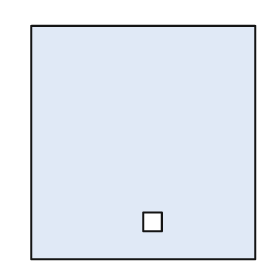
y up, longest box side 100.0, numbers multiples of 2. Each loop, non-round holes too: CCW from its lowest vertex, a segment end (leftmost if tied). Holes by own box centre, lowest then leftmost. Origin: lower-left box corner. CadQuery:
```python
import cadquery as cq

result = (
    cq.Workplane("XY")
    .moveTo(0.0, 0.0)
    .lineTo(96.0, 0.0)
    .lineTo(96.0, 100.0)
    .lineTo(0.0, 100.0)
    .close()
    .moveTo(48.0, 12.0)
    .lineTo(56.0, 12.0)
    .lineTo(56.0, 20.0)
    .lineTo(48.0, 20.0)
    .close()
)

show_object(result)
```